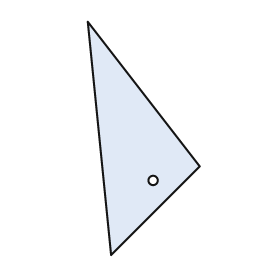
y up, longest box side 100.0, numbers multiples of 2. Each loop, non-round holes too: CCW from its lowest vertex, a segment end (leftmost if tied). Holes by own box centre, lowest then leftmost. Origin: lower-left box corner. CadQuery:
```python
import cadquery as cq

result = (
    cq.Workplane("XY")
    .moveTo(10.0, 0.0)
    .lineTo(48.0, 38.0)
    .lineTo(0.0, 100.0)
    .close()
    .moveTo(28.0, 32.0)
    .circle(2.0)
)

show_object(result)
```